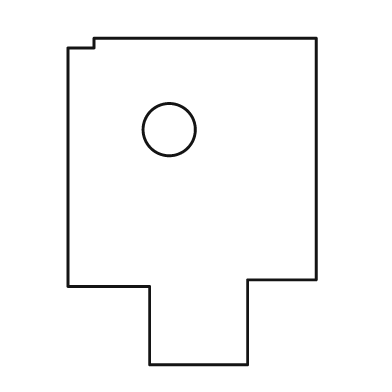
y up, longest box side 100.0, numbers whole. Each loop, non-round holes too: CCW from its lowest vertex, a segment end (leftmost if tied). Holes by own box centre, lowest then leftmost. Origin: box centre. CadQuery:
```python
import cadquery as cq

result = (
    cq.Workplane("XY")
    .moveTo(-13.0, -50.0)
    .lineTo(17.0, -50.0)
    .lineTo(17.0, -24.0)
    .lineTo(38.0, -24.0)
    .lineTo(38.0, 50.0)
    .lineTo(-30.0, 50.0)
    .lineTo(-30.0, 47.0)
    .lineTo(-38.0, 47.0)
    .lineTo(-38.0, -26.0)
    .lineTo(-13.0, -26.0)
    .close()
    .moveTo(-7.0, 22.0)
    .circle(8.0)
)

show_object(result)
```